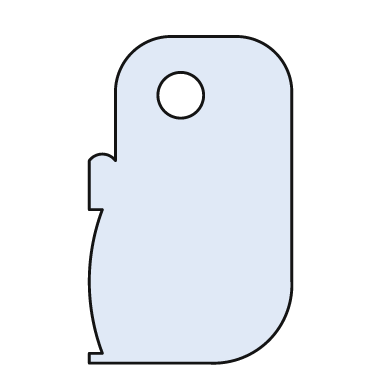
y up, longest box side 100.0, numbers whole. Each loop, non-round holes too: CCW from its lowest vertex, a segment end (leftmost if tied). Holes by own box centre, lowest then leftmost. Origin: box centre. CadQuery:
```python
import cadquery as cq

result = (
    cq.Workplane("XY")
    .moveTo(-31.0, -50.0)
    .lineTo(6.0, -50.0)
    .threePointArc((24.0, -43.0), (31.0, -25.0))
    .lineTo(31.0, 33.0)
    .threePointArc((26.0, 45.0), (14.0, 50.0))
    .lineTo(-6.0, 50.0)
    .threePointArc((-18.0, 45.0), (-23.0, 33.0))
    .lineTo(-23.0, 12.0)
    .threePointArc((-27.0, 14.0), (-31.0, 12.0))
    .lineTo(-31.0, -3.0)
    .lineTo(-27.0, -3.0)
    .threePointArc((-31.0, -25.0), (-27.0, -47.0))
    .lineTo(-31.0, -47.0)
    .close()
    .moveTo(-3.0, 32.0)
    .circle(7.0)
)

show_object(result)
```